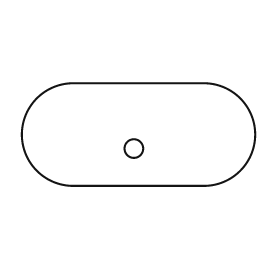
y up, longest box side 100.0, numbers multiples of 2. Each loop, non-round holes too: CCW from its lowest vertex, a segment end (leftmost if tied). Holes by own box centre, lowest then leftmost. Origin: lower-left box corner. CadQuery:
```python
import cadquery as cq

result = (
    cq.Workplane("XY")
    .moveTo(22.0, 0.0)
    .lineTo(78.0, 0.0)
    .threePointArc((100.0, 22.0), (78.0, 44.0))
    .lineTo(22.0, 44.0)
    .threePointArc((0.0, 22.0), (22.0, 0.0))
    .close()
    .moveTo(48.0, 16.0)
    .circle(4.0)
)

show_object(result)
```